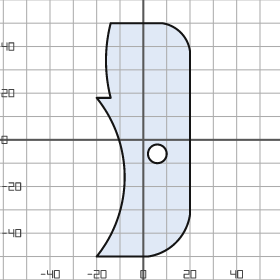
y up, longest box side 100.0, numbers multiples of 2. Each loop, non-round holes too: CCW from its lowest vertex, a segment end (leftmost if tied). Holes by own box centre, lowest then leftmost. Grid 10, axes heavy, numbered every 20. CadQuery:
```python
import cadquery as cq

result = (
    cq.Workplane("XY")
    .moveTo(-20.0, -50.0)
    .lineTo(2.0, -50.0)
    .threePointArc((14.0, -44.0), (20.0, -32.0))
    .lineTo(20.0, 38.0)
    .threePointArc((16.0, 46.0), (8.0, 50.0))
    .lineTo(-14.0, 50.0)
    .threePointArc((-16.0, 34.0), (-14.0, 18.0))
    .lineTo(-20.0, 18.0)
    .threePointArc((-8.0, -16.0), (-20.0, -50.0))
    .close()
    .moveTo(6.0, -6.0)
    .circle(4.0)
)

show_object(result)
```